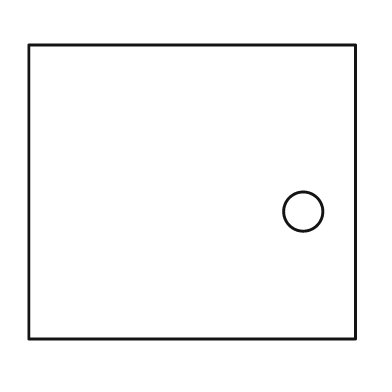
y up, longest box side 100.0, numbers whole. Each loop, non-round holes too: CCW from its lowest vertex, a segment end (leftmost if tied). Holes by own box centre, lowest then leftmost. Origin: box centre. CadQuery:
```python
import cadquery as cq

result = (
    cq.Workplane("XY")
    .moveTo(-50.0, -45.0)
    .lineTo(50.0, -45.0)
    .lineTo(50.0, 45.0)
    .lineTo(-50.0, 45.0)
    .close()
    .moveTo(34.0, -6.0)
    .circle(6.0)
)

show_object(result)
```